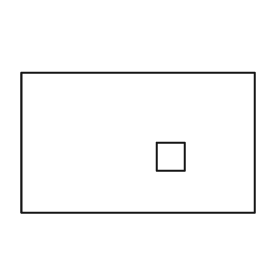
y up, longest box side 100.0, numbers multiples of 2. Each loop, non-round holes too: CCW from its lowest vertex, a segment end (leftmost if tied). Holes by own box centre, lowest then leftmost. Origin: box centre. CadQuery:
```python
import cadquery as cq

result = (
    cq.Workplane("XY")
    .moveTo(-50.0, -30.0)
    .lineTo(50.0, -30.0)
    .lineTo(50.0, 30.0)
    .lineTo(-50.0, 30.0)
    .close()
    .moveTo(8.0, -12.0)
    .lineTo(20.0, -12.0)
    .lineTo(20.0, 0.0)
    .lineTo(8.0, 0.0)
    .close()
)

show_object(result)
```